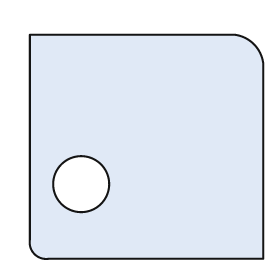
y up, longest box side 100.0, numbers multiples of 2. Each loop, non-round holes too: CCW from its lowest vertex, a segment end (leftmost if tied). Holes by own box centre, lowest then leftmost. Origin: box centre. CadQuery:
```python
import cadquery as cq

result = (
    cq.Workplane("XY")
    .moveTo(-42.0, -48.0)
    .lineTo(50.0, -48.0)
    .lineTo(50.0, 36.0)
    .threePointArc((46.0, 44.0), (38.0, 48.0))
    .lineTo(-50.0, 48.0)
    .lineTo(-50.0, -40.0)
    .threePointArc((-48.0, -46.0), (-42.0, -48.0))
    .close()
    .moveTo(-28.0, -16.0)
    .circle(12.0)
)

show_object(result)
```